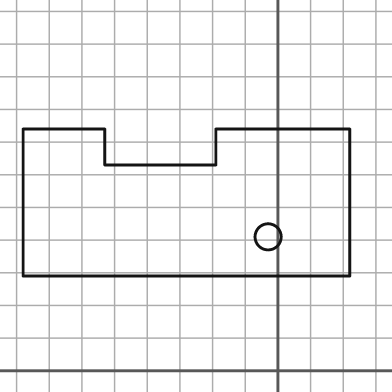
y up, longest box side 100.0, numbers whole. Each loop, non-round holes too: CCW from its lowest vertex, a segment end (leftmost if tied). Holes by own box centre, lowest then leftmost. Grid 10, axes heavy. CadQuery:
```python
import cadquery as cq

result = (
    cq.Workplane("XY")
    .moveTo(-78.0, 29.0)
    .lineTo(22.0, 29.0)
    .lineTo(22.0, 74.0)
    .lineTo(-19.0, 74.0)
    .lineTo(-19.0, 63.0)
    .lineTo(-53.0, 63.0)
    .lineTo(-53.0, 74.0)
    .lineTo(-78.0, 74.0)
    .close()
    .moveTo(-3.0, 41.0)
    .circle(4.0)
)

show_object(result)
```